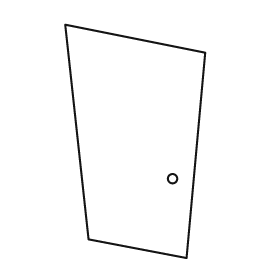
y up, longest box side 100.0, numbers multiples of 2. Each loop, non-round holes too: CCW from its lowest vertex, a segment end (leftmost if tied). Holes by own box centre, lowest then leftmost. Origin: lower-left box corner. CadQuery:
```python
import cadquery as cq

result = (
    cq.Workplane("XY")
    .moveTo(52.0, 0.0)
    .lineTo(60.0, 88.0)
    .lineTo(0.0, 100.0)
    .lineTo(10.0, 8.0)
    .close()
    .moveTo(46.0, 34.0)
    .circle(2.0)
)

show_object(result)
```